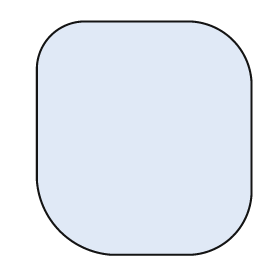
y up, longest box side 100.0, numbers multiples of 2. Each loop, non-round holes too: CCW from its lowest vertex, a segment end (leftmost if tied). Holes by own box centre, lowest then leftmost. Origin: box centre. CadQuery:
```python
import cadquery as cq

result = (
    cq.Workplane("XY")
    .moveTo(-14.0, -50.0)
    .lineTo(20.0, -50.0)
    .threePointArc((38.0, -42.0), (46.0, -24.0))
    .lineTo(46.0, 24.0)
    .threePointArc((38.0, 42.0), (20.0, 50.0))
    .lineTo(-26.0, 50.0)
    .threePointArc((-40.0, 44.0), (-46.0, 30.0))
    .lineTo(-46.0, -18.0)
    .threePointArc((-36.0, -40.0), (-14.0, -50.0))
    .close()
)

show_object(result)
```